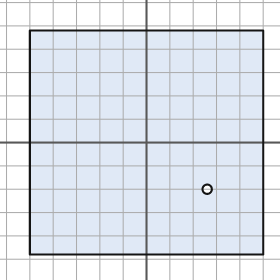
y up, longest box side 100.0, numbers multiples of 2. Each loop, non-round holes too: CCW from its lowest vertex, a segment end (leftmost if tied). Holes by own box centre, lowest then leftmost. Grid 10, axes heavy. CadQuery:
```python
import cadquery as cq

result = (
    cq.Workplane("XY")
    .moveTo(-50.0, -48.0)
    .lineTo(50.0, -48.0)
    .lineTo(50.0, 48.0)
    .lineTo(-50.0, 48.0)
    .close()
    .moveTo(26.0, -20.0)
    .circle(2.0)
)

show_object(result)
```